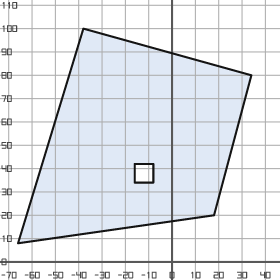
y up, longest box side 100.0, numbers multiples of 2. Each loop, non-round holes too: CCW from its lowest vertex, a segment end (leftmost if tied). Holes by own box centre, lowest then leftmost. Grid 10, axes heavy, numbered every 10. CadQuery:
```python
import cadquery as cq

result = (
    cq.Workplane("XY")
    .moveTo(-66.0, 8.0)
    .lineTo(18.0, 20.0)
    .lineTo(34.0, 80.0)
    .lineTo(-38.0, 100.0)
    .close()
    .moveTo(-16.0, 34.0)
    .lineTo(-8.0, 34.0)
    .lineTo(-8.0, 42.0)
    .lineTo(-16.0, 42.0)
    .close()
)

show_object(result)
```